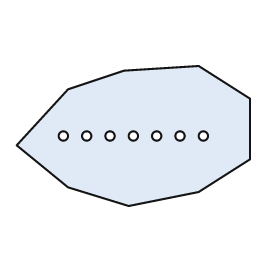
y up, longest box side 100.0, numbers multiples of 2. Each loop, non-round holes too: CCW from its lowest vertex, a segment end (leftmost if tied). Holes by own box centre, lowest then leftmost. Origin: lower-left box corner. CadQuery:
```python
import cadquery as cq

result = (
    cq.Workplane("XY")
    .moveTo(48.0, 0.0)
    .lineTo(78.0, 6.0)
    .lineTo(100.0, 20.0)
    .lineTo(100.0, 46.0)
    .lineTo(78.0, 60.0)
    .lineTo(46.0, 58.0)
    .lineTo(22.0, 50.0)
    .lineTo(0.0, 26.0)
    .lineTo(22.0, 8.0)
    .close()
    .moveTo(20.0, 30.0)
    .circle(2.0)
    .moveTo(30.0, 30.0)
    .circle(2.0)
    .moveTo(40.0, 30.0)
    .circle(2.0)
    .moveTo(50.0, 30.0)
    .circle(2.0)
    .moveTo(60.0, 30.0)
    .circle(2.0)
    .moveTo(70.0, 30.0)
    .circle(2.0)
    .moveTo(80.0, 30.0)
    .circle(2.0)
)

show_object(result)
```